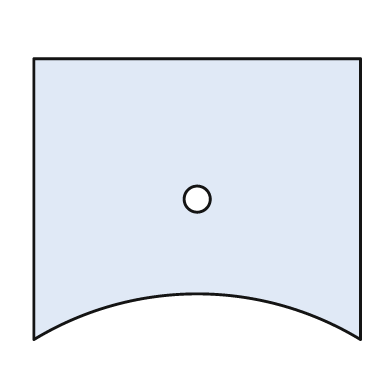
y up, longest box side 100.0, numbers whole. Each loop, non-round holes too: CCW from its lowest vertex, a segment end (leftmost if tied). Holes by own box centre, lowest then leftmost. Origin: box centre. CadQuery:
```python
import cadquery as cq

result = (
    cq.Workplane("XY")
    .moveTo(-50.0, -43.0)
    .threePointArc((0.0, -29.0), (50.0, -43.0))
    .lineTo(50.0, 43.0)
    .lineTo(-50.0, 43.0)
    .close()
    .moveTo(0.0, 0.0)
    .circle(4.0)
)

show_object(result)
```